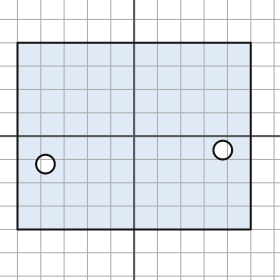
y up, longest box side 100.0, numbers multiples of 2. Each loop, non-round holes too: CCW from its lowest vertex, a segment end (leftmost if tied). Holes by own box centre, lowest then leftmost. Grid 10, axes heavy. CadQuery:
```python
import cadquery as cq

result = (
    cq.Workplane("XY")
    .moveTo(-50.0, -40.0)
    .lineTo(50.0, -40.0)
    .lineTo(50.0, 40.0)
    .lineTo(-50.0, 40.0)
    .close()
    .moveTo(-38.0, -12.0)
    .circle(4.0)
    .moveTo(38.0, -6.0)
    .circle(4.0)
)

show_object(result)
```